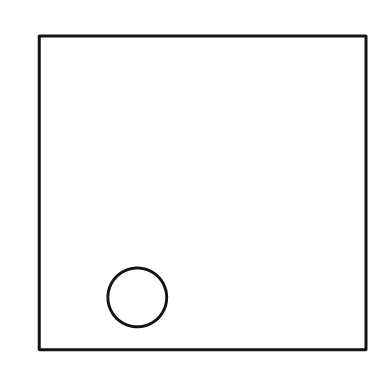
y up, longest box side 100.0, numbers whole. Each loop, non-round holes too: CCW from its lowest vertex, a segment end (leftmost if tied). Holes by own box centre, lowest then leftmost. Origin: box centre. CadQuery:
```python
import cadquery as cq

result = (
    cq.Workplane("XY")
    .moveTo(-50.0, -48.0)
    .lineTo(50.0, -48.0)
    .lineTo(50.0, 48.0)
    .lineTo(-50.0, 48.0)
    .close()
    .moveTo(-20.0, -32.0)
    .circle(9.0)
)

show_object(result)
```